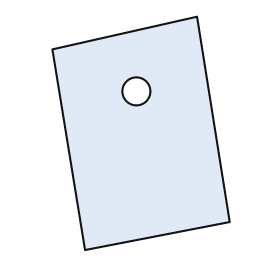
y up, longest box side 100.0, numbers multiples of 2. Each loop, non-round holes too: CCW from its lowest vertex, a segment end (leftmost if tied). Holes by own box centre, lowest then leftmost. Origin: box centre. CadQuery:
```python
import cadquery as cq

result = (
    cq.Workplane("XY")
    .moveTo(-24.0, -50.0)
    .lineTo(38.0, -38.0)
    .lineTo(24.0, 50.0)
    .lineTo(-38.0, 36.0)
    .close()
    .moveTo(-2.0, 18.0)
    .circle(6.0)
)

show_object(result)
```